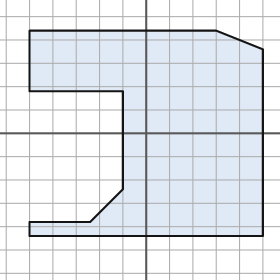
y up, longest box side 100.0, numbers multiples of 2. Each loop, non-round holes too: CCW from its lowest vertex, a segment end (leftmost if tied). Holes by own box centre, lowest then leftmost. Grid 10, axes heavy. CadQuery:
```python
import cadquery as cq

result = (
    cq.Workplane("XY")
    .moveTo(-50.0, -44.0)
    .lineTo(50.0, -44.0)
    .lineTo(50.0, 36.0)
    .lineTo(30.0, 44.0)
    .lineTo(-50.0, 44.0)
    .lineTo(-50.0, 18.0)
    .lineTo(-10.0, 18.0)
    .lineTo(-10.0, -24.0)
    .lineTo(-24.0, -38.0)
    .lineTo(-50.0, -38.0)
    .close()
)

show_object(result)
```